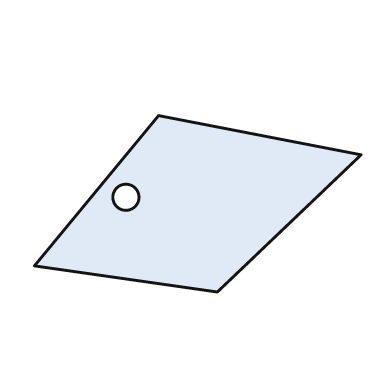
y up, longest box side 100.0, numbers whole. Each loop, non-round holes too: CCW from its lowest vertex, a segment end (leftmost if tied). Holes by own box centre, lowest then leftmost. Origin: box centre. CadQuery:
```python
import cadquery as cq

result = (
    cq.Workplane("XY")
    .moveTo(6.0, -27.0)
    .lineTo(50.0, 15.0)
    .lineTo(-12.0, 27.0)
    .lineTo(-50.0, -19.0)
    .close()
    .moveTo(-22.0, 2.0)
    .circle(4.0)
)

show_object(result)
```